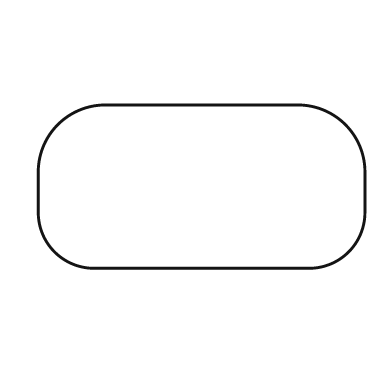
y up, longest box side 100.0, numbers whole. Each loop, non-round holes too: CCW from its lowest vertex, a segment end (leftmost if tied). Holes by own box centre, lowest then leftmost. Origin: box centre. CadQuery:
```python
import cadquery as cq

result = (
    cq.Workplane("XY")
    .moveTo(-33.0, -25.0)
    .lineTo(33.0, -25.0)
    .threePointArc((45.0, -20.0), (50.0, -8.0))
    .lineTo(50.0, 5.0)
    .threePointArc((44.0, 19.0), (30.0, 25.0))
    .lineTo(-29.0, 25.0)
    .threePointArc((-44.0, 19.0), (-50.0, 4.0))
    .lineTo(-50.0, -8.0)
    .threePointArc((-45.0, -20.0), (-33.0, -25.0))
    .close()
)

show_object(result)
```